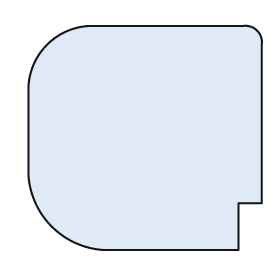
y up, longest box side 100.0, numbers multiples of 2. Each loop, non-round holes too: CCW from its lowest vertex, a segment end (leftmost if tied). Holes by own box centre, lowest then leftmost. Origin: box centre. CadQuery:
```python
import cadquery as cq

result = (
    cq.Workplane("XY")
    .moveTo(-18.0, -48.0)
    .lineTo(40.0, -48.0)
    .lineTo(40.0, -28.0)
    .lineTo(50.0, -28.0)
    .lineTo(50.0, 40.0)
    .threePointArc((48.0, 46.0), (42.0, 48.0))
    .lineTo(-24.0, 48.0)
    .threePointArc((-42.0, 40.0), (-50.0, 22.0))
    .lineTo(-50.0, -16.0)
    .threePointArc((-40.0, -38.0), (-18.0, -48.0))
    .close()
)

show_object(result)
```